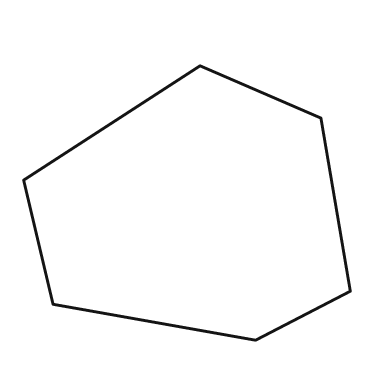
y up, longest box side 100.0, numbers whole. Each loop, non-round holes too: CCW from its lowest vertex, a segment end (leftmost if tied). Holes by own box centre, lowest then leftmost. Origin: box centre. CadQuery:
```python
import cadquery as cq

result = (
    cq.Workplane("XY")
    .moveTo(21.0, -42.0)
    .lineTo(50.0, -27.0)
    .lineTo(41.0, 26.0)
    .lineTo(4.0, 42.0)
    .lineTo(-50.0, 7.0)
    .lineTo(-41.0, -31.0)
    .close()
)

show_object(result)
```